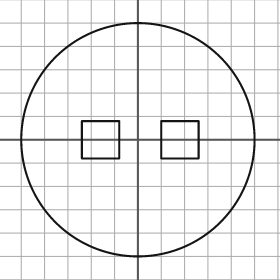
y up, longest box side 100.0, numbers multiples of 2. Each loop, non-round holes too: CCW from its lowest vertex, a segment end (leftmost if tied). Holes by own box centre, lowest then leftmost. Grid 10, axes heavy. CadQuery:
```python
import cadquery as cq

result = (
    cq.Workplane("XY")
    .moveTo(0.0, 0.0)
    .circle(50.0)
    .moveTo(-24.0, -8.0)
    .lineTo(-8.0, -8.0)
    .lineTo(-8.0, 8.0)
    .lineTo(-24.0, 8.0)
    .close()
    .moveTo(10.0, -8.0)
    .lineTo(26.0, -8.0)
    .lineTo(26.0, 8.0)
    .lineTo(10.0, 8.0)
    .close()
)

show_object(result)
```